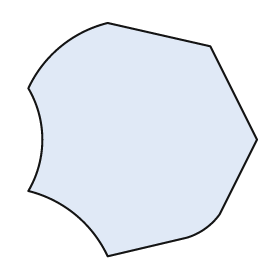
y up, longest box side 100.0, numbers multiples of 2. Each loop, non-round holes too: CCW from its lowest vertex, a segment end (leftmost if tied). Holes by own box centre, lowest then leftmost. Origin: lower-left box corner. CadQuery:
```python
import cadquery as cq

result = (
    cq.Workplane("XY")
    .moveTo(34.0, 0.0)
    .lineTo(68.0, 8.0)
    .threePointArc((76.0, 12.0), (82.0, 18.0))
    .lineTo(98.0, 50.0)
    .lineTo(78.0, 90.0)
    .lineTo(34.0, 100.0)
    .threePointArc((14.0, 90.0), (0.0, 72.0))
    .threePointArc((6.0, 50.0), (0.0, 28.0))
    .threePointArc((20.0, 18.0), (34.0, 0.0))
    .close()
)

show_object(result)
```